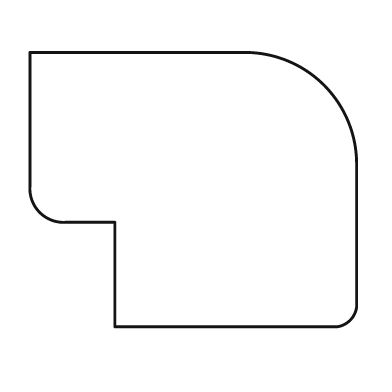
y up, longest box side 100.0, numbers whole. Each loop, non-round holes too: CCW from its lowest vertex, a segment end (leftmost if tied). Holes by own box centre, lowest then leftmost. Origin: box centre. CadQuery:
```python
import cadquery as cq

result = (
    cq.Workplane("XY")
    .moveTo(-24.0, -42.0)
    .lineTo(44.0, -42.0)
    .threePointArc((48.0, -40.0), (50.0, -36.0))
    .lineTo(50.0, 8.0)
    .threePointArc((40.0, 32.0), (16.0, 42.0))
    .lineTo(-50.0, 42.0)
    .lineTo(-50.0, 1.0)
    .threePointArc((-47.0, -7.0), (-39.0, -10.0))
    .lineTo(-24.0, -10.0)
    .close()
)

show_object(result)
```